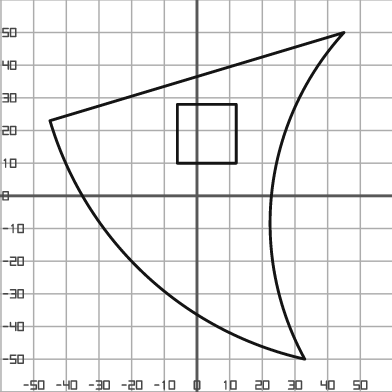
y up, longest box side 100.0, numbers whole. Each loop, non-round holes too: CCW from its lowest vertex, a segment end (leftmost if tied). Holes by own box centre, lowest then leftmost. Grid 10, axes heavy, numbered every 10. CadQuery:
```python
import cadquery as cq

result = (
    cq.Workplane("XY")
    .moveTo(33.0, -50.0)
    .threePointArc((23.0, 2.0), (45.0, 50.0))
    .lineTo(-45.0, 23.0)
    .threePointArc((-16.0, -24.0), (33.0, -50.0))
    .close()
    .moveTo(-6.0, 10.0)
    .lineTo(12.0, 10.0)
    .lineTo(12.0, 28.0)
    .lineTo(-6.0, 28.0)
    .close()
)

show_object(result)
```